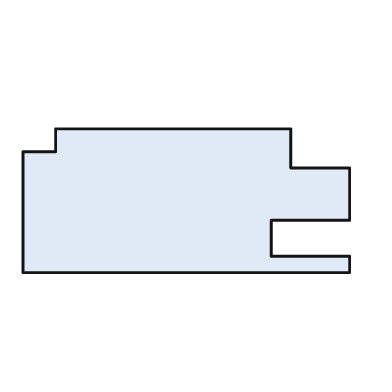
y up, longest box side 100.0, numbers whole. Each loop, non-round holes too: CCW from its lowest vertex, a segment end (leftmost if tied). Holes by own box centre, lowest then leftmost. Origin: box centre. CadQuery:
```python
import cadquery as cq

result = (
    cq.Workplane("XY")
    .moveTo(-50.0, -22.0)
    .lineTo(50.0, -22.0)
    .lineTo(50.0, -17.0)
    .lineTo(26.0, -17.0)
    .lineTo(26.0, -6.0)
    .lineTo(50.0, -6.0)
    .lineTo(50.0, 10.0)
    .lineTo(32.0, 10.0)
    .lineTo(32.0, 22.0)
    .lineTo(-40.0, 22.0)
    .lineTo(-40.0, 15.0)
    .lineTo(-50.0, 15.0)
    .close()
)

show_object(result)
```